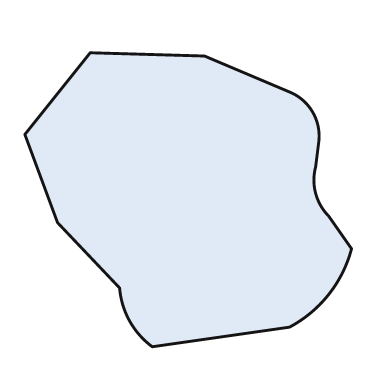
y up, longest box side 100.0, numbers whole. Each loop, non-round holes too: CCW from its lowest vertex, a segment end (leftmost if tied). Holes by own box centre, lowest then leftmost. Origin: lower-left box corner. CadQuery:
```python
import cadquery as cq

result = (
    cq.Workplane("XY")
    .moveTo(39.0, 0.0)
    .lineTo(81.0, 6.0)
    .threePointArc((93.0, 16.0), (100.0, 30.0))
    .lineTo(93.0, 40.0)
    .threePointArc((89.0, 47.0), (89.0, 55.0))
    .lineTo(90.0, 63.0)
    .threePointArc((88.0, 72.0), (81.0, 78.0))
    .lineTo(55.0, 89.0)
    .lineTo(20.0, 90.0)
    .lineTo(0.0, 65.0)
    .lineTo(10.0, 38.0)
    .lineTo(29.0, 18.0)
    .threePointArc((32.0, 8.0), (39.0, 0.0))
    .close()
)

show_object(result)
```